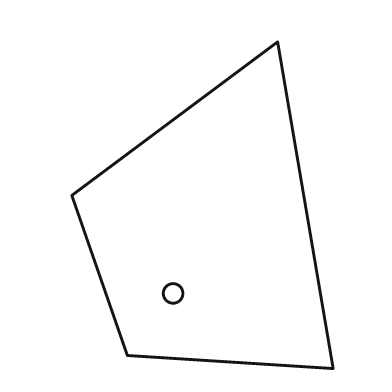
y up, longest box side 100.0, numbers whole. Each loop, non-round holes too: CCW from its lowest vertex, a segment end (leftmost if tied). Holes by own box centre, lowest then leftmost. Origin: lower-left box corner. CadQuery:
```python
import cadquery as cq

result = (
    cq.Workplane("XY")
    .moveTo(80.0, 0.0)
    .lineTo(63.0, 100.0)
    .lineTo(0.0, 53.0)
    .lineTo(17.0, 4.0)
    .close()
    .moveTo(31.0, 23.0)
    .circle(3.0)
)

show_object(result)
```